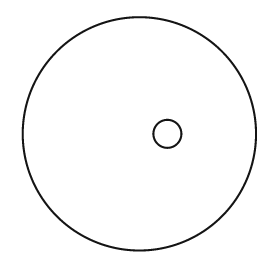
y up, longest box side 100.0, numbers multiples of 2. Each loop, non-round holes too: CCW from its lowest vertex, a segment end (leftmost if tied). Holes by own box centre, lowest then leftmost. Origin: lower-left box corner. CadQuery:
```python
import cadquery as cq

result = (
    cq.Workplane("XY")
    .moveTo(50.0, 50.0)
    .circle(50.0)
    .moveTo(62.0, 50.0)
    .circle(6.0)
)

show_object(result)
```